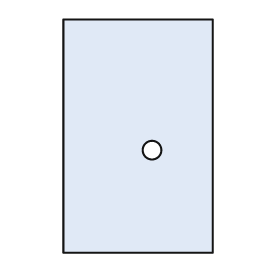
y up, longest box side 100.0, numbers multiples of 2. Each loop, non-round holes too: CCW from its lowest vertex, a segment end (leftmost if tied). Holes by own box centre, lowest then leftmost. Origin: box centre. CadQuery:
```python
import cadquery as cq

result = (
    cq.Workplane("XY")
    .moveTo(-32.0, -50.0)
    .lineTo(32.0, -50.0)
    .lineTo(32.0, 50.0)
    .lineTo(-32.0, 50.0)
    .close()
    .moveTo(6.0, -6.0)
    .circle(4.0)
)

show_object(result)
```